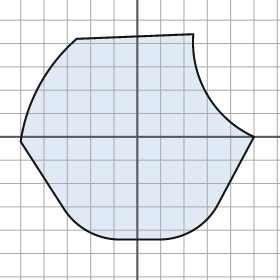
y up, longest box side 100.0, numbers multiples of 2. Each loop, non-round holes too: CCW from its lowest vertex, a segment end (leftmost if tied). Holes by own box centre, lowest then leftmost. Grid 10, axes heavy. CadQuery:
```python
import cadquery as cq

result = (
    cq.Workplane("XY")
    .moveTo(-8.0, -44.0)
    .lineTo(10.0, -44.0)
    .threePointArc((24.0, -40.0), (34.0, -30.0))
    .lineTo(50.0, 0.0)
    .threePointArc((30.0, 18.0), (24.0, 44.0))
    .lineTo(-26.0, 42.0)
    .threePointArc((-42.0, 22.0), (-50.0, -2.0))
    .lineTo(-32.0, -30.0)
    .threePointArc((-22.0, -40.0), (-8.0, -44.0))
    .close()
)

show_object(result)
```